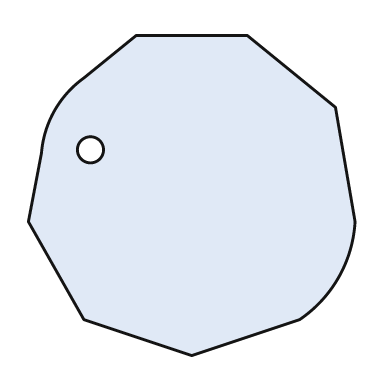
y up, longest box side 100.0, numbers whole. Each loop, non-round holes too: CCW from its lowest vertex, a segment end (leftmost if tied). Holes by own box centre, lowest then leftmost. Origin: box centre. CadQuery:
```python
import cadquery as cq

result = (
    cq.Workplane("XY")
    .moveTo(0.0, -49.0)
    .lineTo(33.0, -38.0)
    .threePointArc((45.0, -25.0), (50.0, -8.0))
    .lineTo(44.0, 27.0)
    .lineTo(17.0, 49.0)
    .lineTo(-17.0, 49.0)
    .lineTo(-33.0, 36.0)
    .threePointArc((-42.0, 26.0), (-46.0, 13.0))
    .lineTo(-50.0, -8.0)
    .lineTo(-33.0, -38.0)
    .close()
    .moveTo(-31.0, 14.0)
    .circle(4.0)
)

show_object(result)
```